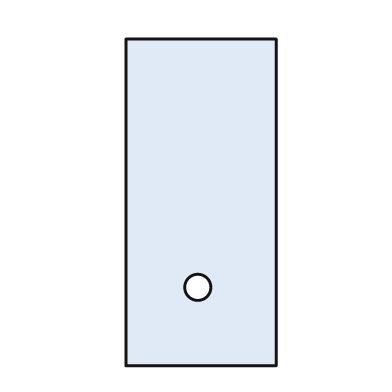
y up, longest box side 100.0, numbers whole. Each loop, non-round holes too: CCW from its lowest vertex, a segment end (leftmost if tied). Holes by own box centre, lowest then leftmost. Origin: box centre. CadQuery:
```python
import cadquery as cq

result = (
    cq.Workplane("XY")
    .moveTo(-23.0, -50.0)
    .lineTo(23.0, -50.0)
    .lineTo(23.0, 50.0)
    .lineTo(-23.0, 50.0)
    .close()
    .moveTo(-1.0, -26.0)
    .circle(4.0)
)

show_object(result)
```